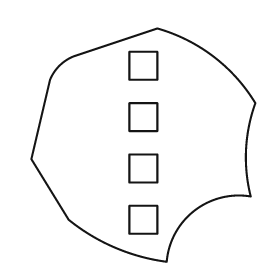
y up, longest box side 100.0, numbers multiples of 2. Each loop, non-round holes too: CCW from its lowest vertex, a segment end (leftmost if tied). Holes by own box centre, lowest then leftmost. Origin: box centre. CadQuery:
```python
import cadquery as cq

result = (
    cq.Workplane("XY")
    .moveTo(10.0, -50.0)
    .threePointArc((22.0, -28.0), (46.0, -22.0))
    .threePointArc((44.0, -2.0), (48.0, 18.0))
    .threePointArc((30.0, 38.0), (6.0, 50.0))
    .lineTo(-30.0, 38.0)
    .threePointArc((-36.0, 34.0), (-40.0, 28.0))
    .lineTo(-48.0, -6.0)
    .lineTo(-32.0, -32.0)
    .threePointArc((-12.0, -44.0), (10.0, -50.0))
    .close()
    .moveTo(-6.0, -38.0)
    .lineTo(6.0, -38.0)
    .lineTo(6.0, -26.0)
    .lineTo(-6.0, -26.0)
    .close()
    .moveTo(-6.0, -16.0)
    .lineTo(6.0, -16.0)
    .lineTo(6.0, -4.0)
    .lineTo(-6.0, -4.0)
    .close()
    .moveTo(-6.0, 6.0)
    .lineTo(6.0, 6.0)
    .lineTo(6.0, 18.0)
    .lineTo(-6.0, 18.0)
    .close()
    .moveTo(-6.0, 28.0)
    .lineTo(6.0, 28.0)
    .lineTo(6.0, 40.0)
    .lineTo(-6.0, 40.0)
    .close()
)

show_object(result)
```